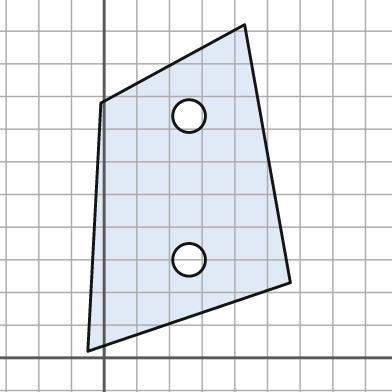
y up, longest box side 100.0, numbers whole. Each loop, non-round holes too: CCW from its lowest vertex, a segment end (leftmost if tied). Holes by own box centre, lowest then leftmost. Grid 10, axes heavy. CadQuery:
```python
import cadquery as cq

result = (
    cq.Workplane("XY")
    .moveTo(-5.0, 2.0)
    .lineTo(57.0, 23.0)
    .lineTo(43.0, 102.0)
    .lineTo(-1.0, 78.0)
    .close()
    .moveTo(26.0, 30.0)
    .circle(5.0)
    .moveTo(26.0, 74.0)
    .circle(5.0)
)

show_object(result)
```